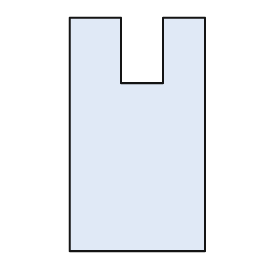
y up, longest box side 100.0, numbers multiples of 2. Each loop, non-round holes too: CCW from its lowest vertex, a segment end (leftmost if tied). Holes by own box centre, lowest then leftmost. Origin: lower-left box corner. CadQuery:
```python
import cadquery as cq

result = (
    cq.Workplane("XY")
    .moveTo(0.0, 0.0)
    .lineTo(58.0, 0.0)
    .lineTo(58.0, 100.0)
    .lineTo(40.0, 100.0)
    .lineTo(40.0, 72.0)
    .lineTo(22.0, 72.0)
    .lineTo(22.0, 100.0)
    .lineTo(0.0, 100.0)
    .close()
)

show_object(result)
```